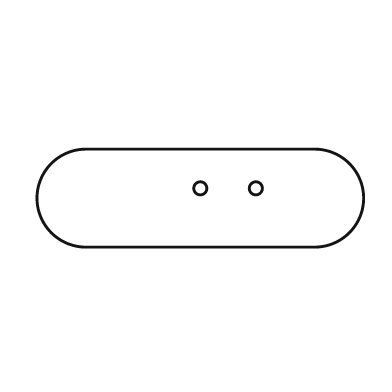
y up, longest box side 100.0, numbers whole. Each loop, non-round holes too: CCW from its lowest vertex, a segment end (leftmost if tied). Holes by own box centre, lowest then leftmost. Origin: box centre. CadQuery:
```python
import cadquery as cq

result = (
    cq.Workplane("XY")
    .moveTo(-35.0, -15.0)
    .lineTo(35.0, -15.0)
    .threePointArc((50.0, 0.0), (35.0, 15.0))
    .lineTo(-35.0, 15.0)
    .threePointArc((-50.0, 0.0), (-35.0, -15.0))
    .close()
    .moveTo(0.0, 3.0)
    .circle(2.0)
    .moveTo(17.0, 3.0)
    .circle(2.0)
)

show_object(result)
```